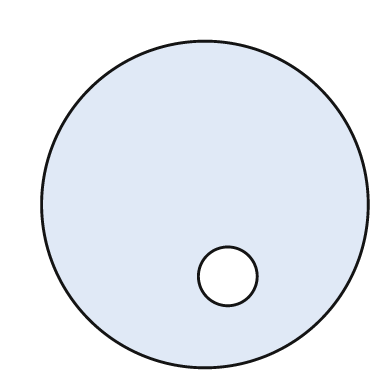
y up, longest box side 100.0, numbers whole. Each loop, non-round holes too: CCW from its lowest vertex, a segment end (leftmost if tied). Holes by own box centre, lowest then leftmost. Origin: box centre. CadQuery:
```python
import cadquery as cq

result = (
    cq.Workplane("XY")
    .moveTo(0.0, 0.0)
    .circle(50.0)
    .moveTo(7.0, -22.0)
    .circle(9.0)
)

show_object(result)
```